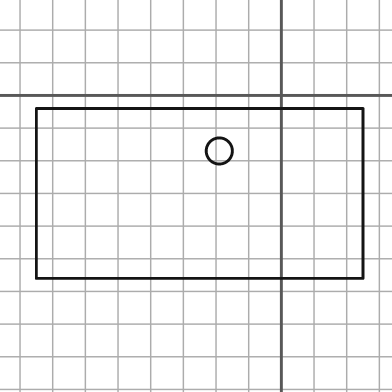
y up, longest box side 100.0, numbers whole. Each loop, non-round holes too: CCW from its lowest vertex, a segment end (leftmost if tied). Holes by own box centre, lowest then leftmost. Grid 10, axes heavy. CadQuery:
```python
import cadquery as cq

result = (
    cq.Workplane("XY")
    .moveTo(-75.0, -56.0)
    .lineTo(25.0, -56.0)
    .lineTo(25.0, -4.0)
    .lineTo(-75.0, -4.0)
    .close()
    .moveTo(-19.0, -17.0)
    .circle(4.0)
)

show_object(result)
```